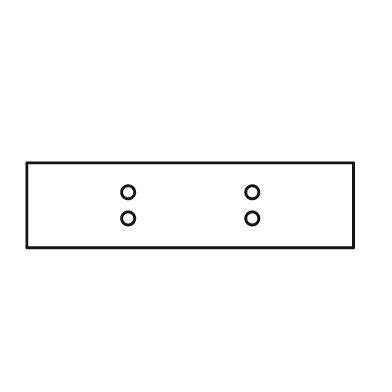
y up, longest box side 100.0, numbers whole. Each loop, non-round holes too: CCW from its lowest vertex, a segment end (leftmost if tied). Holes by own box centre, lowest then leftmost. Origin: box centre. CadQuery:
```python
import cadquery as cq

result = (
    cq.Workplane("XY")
    .moveTo(-50.0, -13.0)
    .lineTo(50.0, -13.0)
    .lineTo(50.0, 13.0)
    .lineTo(-50.0, 13.0)
    .close()
    .moveTo(-19.0, -4.0)
    .circle(2.0)
    .moveTo(19.0, -4.0)
    .circle(2.0)
    .moveTo(-19.0, 4.0)
    .circle(2.0)
    .moveTo(19.0, 4.0)
    .circle(2.0)
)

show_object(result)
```